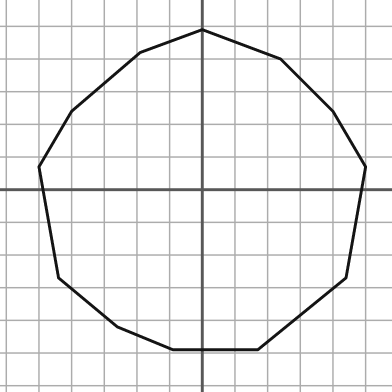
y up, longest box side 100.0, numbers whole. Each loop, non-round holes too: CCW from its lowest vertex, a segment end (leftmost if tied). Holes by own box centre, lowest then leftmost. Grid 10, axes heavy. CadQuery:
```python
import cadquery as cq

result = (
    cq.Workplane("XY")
    .moveTo(-9.0, -49.0)
    .lineTo(17.0, -49.0)
    .lineTo(44.0, -27.0)
    .lineTo(50.0, 7.0)
    .lineTo(40.0, 24.0)
    .lineTo(24.0, 40.0)
    .lineTo(0.0, 49.0)
    .lineTo(-19.0, 42.0)
    .lineTo(-40.0, 24.0)
    .lineTo(-50.0, 7.0)
    .lineTo(-44.0, -27.0)
    .lineTo(-26.0, -42.0)
    .close()
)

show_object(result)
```